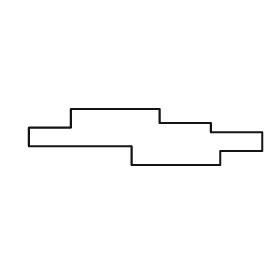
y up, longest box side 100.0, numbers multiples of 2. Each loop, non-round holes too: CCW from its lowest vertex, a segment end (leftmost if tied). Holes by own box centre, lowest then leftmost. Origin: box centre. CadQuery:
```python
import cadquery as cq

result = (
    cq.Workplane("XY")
    .moveTo(-6.0, -12.0)
    .lineTo(32.0, -12.0)
    .lineTo(32.0, -6.0)
    .lineTo(50.0, -6.0)
    .lineTo(50.0, 2.0)
    .lineTo(28.0, 2.0)
    .lineTo(28.0, 6.0)
    .lineTo(6.0, 6.0)
    .lineTo(6.0, 12.0)
    .lineTo(-32.0, 12.0)
    .lineTo(-32.0, 4.0)
    .lineTo(-50.0, 4.0)
    .lineTo(-50.0, -4.0)
    .lineTo(-6.0, -4.0)
    .close()
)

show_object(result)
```